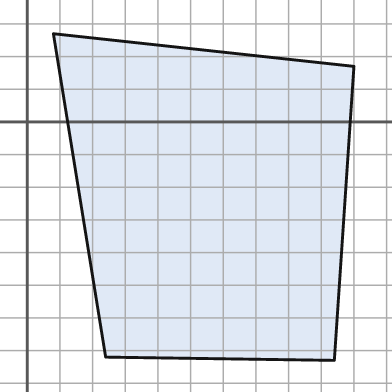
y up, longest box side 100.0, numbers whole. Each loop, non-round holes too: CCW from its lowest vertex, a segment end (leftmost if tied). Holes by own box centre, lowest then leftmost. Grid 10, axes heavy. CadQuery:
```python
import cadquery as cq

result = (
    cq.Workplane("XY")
    .moveTo(94.0, -73.0)
    .lineTo(100.0, 17.0)
    .lineTo(8.0, 27.0)
    .lineTo(24.0, -72.0)
    .close()
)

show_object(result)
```